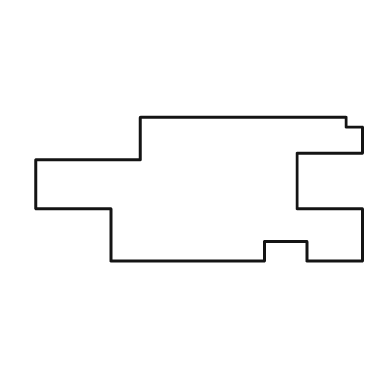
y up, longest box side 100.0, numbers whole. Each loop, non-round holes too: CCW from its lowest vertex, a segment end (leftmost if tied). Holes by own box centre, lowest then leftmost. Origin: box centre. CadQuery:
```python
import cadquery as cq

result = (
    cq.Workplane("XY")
    .moveTo(-27.0, -22.0)
    .lineTo(20.0, -22.0)
    .lineTo(20.0, -16.0)
    .lineTo(33.0, -16.0)
    .lineTo(33.0, -22.0)
    .lineTo(50.0, -22.0)
    .lineTo(50.0, -6.0)
    .lineTo(30.0, -6.0)
    .lineTo(30.0, 11.0)
    .lineTo(50.0, 11.0)
    .lineTo(50.0, 19.0)
    .lineTo(45.0, 19.0)
    .lineTo(45.0, 22.0)
    .lineTo(-18.0, 22.0)
    .lineTo(-18.0, 9.0)
    .lineTo(-50.0, 9.0)
    .lineTo(-50.0, -6.0)
    .lineTo(-27.0, -6.0)
    .close()
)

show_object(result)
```